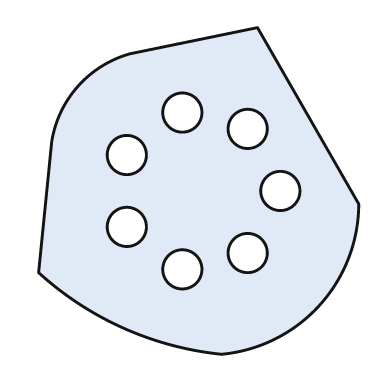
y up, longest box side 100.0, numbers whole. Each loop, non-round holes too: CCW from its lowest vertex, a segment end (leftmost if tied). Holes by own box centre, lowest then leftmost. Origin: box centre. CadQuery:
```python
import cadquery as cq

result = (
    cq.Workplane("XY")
    .moveTo(7.0, -50.0)
    .threePointArc((37.0, -35.0), (49.0, -4.0))
    .lineTo(18.0, 50.0)
    .lineTo(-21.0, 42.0)
    .threePointArc((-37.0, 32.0), (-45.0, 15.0))
    .lineTo(-49.0, -25.0)
    .threePointArc((-23.0, -42.0), (7.0, -50.0))
    .close()
    .moveTo(-5.0, -24.0)
    .circle(6.0)
    .moveTo(15.0, -19.0)
    .circle(6.0)
    .moveTo(-22.0, -11.0)
    .circle(6.0)
    .moveTo(25.0, 0.0)
    .circle(6.0)
    .moveTo(-22.0, 11.0)
    .circle(6.0)
    .moveTo(15.0, 19.0)
    .circle(6.0)
    .moveTo(-5.0, 24.0)
    .circle(6.0)
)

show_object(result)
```